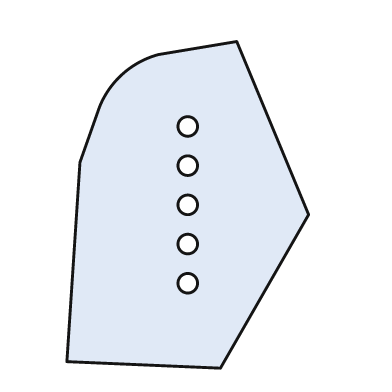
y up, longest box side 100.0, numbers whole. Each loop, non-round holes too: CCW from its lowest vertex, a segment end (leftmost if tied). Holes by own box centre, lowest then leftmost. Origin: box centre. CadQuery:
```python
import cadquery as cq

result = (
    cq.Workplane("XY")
    .moveTo(10.0, -50.0)
    .lineTo(37.0, -3.0)
    .lineTo(15.0, 50.0)
    .lineTo(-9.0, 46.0)
    .threePointArc((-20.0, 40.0), (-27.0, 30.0))
    .lineTo(-33.0, 13.0)
    .lineTo(-37.0, -48.0)
    .close()
    .moveTo(0.0, -24.0)
    .circle(3.0)
    .moveTo(0.0, -12.0)
    .circle(3.0)
    .moveTo(0.0, 0.0)
    .circle(3.0)
    .moveTo(0.0, 12.0)
    .circle(3.0)
    .moveTo(0.0, 24.0)
    .circle(3.0)
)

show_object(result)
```